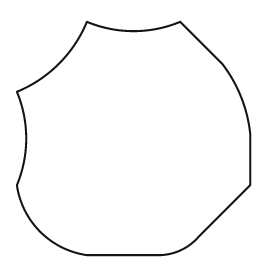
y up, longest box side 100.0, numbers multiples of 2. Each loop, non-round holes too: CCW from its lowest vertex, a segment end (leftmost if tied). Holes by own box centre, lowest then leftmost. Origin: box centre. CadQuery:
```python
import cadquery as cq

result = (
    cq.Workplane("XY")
    .moveTo(-20.0, -50.0)
    .lineTo(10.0, -50.0)
    .threePointArc((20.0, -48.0), (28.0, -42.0))
    .lineTo(50.0, -20.0)
    .lineTo(50.0, 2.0)
    .threePointArc((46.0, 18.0), (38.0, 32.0))
    .lineTo(20.0, 50.0)
    .threePointArc((0.0, 46.0), (-20.0, 50.0))
    .threePointArc((-32.0, 32.0), (-50.0, 20.0))
    .threePointArc((-46.0, 0.0), (-50.0, -20.0))
    .threePointArc((-40.0, -40.0), (-20.0, -50.0))
    .close()
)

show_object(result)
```